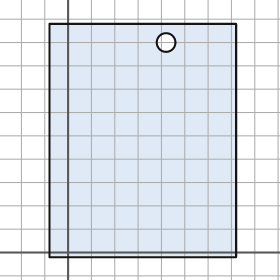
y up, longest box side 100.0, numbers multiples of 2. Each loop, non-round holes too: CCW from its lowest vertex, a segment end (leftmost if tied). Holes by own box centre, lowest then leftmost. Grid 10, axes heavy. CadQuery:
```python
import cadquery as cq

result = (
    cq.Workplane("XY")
    .moveTo(-8.0, -2.0)
    .lineTo(72.0, -2.0)
    .lineTo(72.0, 98.0)
    .lineTo(-8.0, 98.0)
    .close()
    .moveTo(42.0, 90.0)
    .circle(4.0)
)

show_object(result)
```